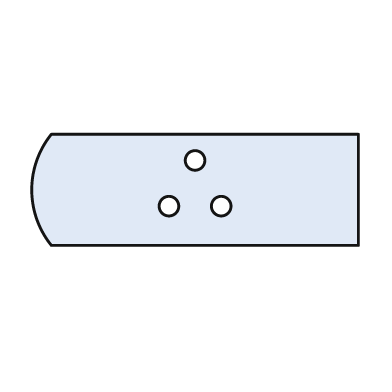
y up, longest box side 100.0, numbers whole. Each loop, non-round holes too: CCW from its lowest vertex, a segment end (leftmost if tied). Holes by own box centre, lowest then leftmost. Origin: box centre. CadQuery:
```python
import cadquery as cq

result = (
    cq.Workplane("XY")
    .moveTo(-44.0, -17.0)
    .lineTo(50.0, -17.0)
    .lineTo(50.0, 17.0)
    .lineTo(-44.0, 17.0)
    .threePointArc((-50.0, 0.0), (-44.0, -17.0))
    .close()
    .moveTo(-8.0, -5.0)
    .circle(3.0)
    .moveTo(8.0, -5.0)
    .circle(3.0)
    .moveTo(0.0, 9.0)
    .circle(3.0)
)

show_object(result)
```